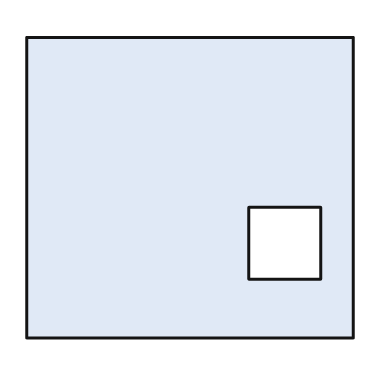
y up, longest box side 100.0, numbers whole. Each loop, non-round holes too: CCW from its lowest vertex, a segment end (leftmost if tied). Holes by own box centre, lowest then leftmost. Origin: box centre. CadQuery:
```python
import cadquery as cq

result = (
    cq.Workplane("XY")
    .moveTo(-50.0, -46.0)
    .lineTo(50.0, -46.0)
    .lineTo(50.0, 46.0)
    .lineTo(-50.0, 46.0)
    .close()
    .moveTo(18.0, -28.0)
    .lineTo(40.0, -28.0)
    .lineTo(40.0, -6.0)
    .lineTo(18.0, -6.0)
    .close()
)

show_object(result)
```